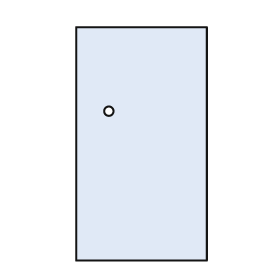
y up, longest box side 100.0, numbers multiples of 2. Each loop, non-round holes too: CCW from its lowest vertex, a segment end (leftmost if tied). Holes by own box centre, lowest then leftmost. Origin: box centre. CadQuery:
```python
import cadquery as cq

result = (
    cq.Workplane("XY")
    .moveTo(-28.0, -50.0)
    .lineTo(28.0, -50.0)
    .lineTo(28.0, 50.0)
    .lineTo(-28.0, 50.0)
    .close()
    .moveTo(-14.0, 14.0)
    .circle(2.0)
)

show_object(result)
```